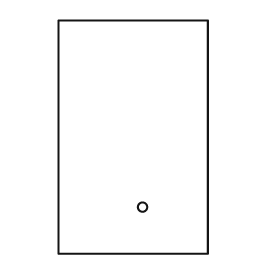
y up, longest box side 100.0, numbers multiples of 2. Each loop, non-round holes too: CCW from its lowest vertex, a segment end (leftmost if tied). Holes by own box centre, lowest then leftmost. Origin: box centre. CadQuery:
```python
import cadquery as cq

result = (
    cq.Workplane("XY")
    .moveTo(-32.0, -50.0)
    .lineTo(32.0, -50.0)
    .lineTo(32.0, 50.0)
    .lineTo(-32.0, 50.0)
    .close()
    .moveTo(4.0, -30.0)
    .circle(2.0)
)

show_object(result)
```